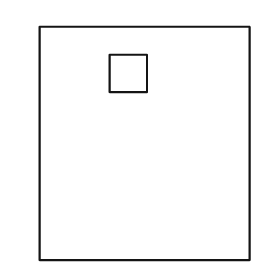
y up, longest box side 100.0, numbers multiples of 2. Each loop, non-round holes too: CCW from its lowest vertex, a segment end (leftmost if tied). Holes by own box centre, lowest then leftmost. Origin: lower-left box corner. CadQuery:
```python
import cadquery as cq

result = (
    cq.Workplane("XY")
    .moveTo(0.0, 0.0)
    .lineTo(90.0, 0.0)
    .lineTo(90.0, 100.0)
    .lineTo(0.0, 100.0)
    .close()
    .moveTo(30.0, 72.0)
    .lineTo(46.0, 72.0)
    .lineTo(46.0, 88.0)
    .lineTo(30.0, 88.0)
    .close()
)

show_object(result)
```